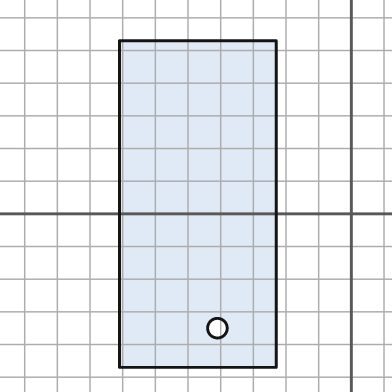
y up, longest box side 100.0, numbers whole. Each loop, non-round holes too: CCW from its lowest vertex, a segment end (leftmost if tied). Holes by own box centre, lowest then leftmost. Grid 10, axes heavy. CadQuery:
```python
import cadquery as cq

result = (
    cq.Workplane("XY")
    .moveTo(-71.0, -47.0)
    .lineTo(-23.0, -47.0)
    .lineTo(-23.0, 53.0)
    .lineTo(-71.0, 53.0)
    .close()
    .moveTo(-41.0, -35.0)
    .circle(3.0)
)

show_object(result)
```